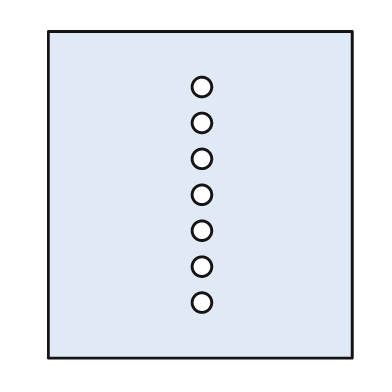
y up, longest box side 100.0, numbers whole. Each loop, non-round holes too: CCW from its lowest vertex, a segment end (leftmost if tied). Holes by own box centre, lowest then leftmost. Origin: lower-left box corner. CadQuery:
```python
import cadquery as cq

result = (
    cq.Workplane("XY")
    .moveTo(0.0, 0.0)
    .lineTo(93.0, 0.0)
    .lineTo(93.0, 100.0)
    .lineTo(0.0, 100.0)
    .close()
    .moveTo(47.0, 17.0)
    .circle(3.0)
    .moveTo(47.0, 28.0)
    .circle(3.0)
    .moveTo(47.0, 39.0)
    .circle(3.0)
    .moveTo(47.0, 50.0)
    .circle(3.0)
    .moveTo(47.0, 61.0)
    .circle(3.0)
    .moveTo(47.0, 72.0)
    .circle(3.0)
    .moveTo(47.0, 83.0)
    .circle(3.0)
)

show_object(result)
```